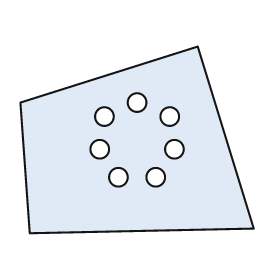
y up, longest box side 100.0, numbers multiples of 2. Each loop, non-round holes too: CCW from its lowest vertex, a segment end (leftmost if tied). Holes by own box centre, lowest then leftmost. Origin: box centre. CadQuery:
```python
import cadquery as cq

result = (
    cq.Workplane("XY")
    .moveTo(-46.0, -40.0)
    .lineTo(50.0, -38.0)
    .lineTo(26.0, 40.0)
    .lineTo(-50.0, 16.0)
    .close()
    .moveTo(-8.0, -16.0)
    .circle(4.0)
    .moveTo(8.0, -16.0)
    .circle(4.0)
    .moveTo(-16.0, -4.0)
    .circle(4.0)
    .moveTo(16.0, -4.0)
    .circle(4.0)
    .moveTo(-14.0, 10.0)
    .circle(4.0)
    .moveTo(14.0, 10.0)
    .circle(4.0)
    .moveTo(0.0, 16.0)
    .circle(4.0)
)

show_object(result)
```